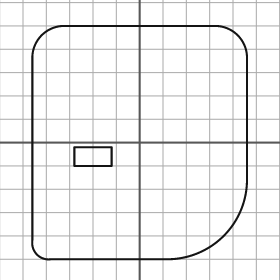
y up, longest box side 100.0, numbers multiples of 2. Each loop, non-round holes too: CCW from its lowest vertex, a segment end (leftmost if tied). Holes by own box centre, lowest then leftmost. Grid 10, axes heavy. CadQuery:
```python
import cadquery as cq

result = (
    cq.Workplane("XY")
    .moveTo(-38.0, -50.0)
    .lineTo(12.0, -50.0)
    .threePointArc((36.0, -40.0), (46.0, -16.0))
    .lineTo(46.0, 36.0)
    .threePointArc((42.0, 46.0), (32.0, 50.0))
    .lineTo(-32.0, 50.0)
    .threePointArc((-42.0, 46.0), (-46.0, 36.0))
    .lineTo(-46.0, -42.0)
    .threePointArc((-44.0, -48.0), (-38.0, -50.0))
    .close()
    .moveTo(-28.0, -10.0)
    .lineTo(-12.0, -10.0)
    .lineTo(-12.0, -2.0)
    .lineTo(-28.0, -2.0)
    .close()
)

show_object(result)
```